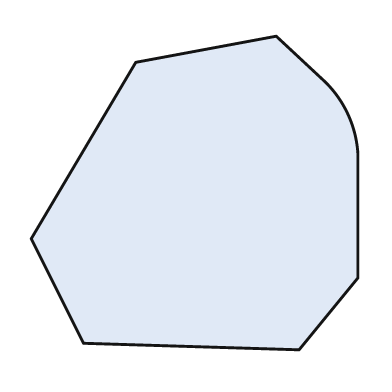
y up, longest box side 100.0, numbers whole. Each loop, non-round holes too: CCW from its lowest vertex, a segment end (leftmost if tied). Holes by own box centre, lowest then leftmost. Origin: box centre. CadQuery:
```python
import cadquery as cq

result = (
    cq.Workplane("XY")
    .moveTo(32.0, -48.0)
    .lineTo(50.0, -26.0)
    .lineTo(50.0, 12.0)
    .threePointArc((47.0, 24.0), (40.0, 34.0))
    .lineTo(25.0, 48.0)
    .lineTo(-18.0, 40.0)
    .lineTo(-50.0, -14.0)
    .lineTo(-34.0, -46.0)
    .close()
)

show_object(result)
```